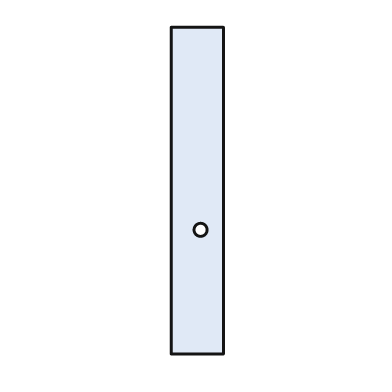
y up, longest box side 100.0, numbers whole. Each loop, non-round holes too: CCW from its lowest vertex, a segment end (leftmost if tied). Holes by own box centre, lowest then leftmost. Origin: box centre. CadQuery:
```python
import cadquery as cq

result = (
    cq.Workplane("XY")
    .moveTo(-8.0, -50.0)
    .lineTo(8.0, -50.0)
    .lineTo(8.0, 50.0)
    .lineTo(-8.0, 50.0)
    .close()
    .moveTo(1.0, -12.0)
    .circle(2.0)
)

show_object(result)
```